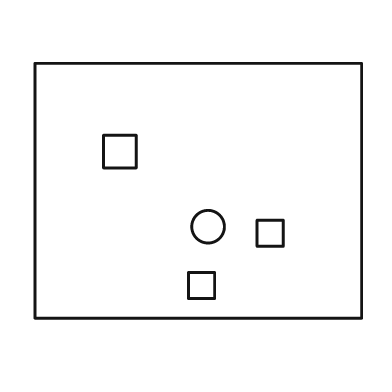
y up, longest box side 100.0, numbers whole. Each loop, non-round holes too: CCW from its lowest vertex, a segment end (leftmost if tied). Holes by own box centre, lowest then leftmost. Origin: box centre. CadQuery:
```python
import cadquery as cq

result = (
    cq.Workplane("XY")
    .moveTo(-50.0, -39.0)
    .lineTo(50.0, -39.0)
    .lineTo(50.0, 39.0)
    .lineTo(-50.0, 39.0)
    .close()
    .moveTo(-3.0, -33.0)
    .lineTo(5.0, -33.0)
    .lineTo(5.0, -25.0)
    .lineTo(-3.0, -25.0)
    .close()
    .moveTo(18.0, -17.0)
    .lineTo(26.0, -17.0)
    .lineTo(26.0, -9.0)
    .lineTo(18.0, -9.0)
    .close()
    .moveTo(3.0, -11.0)
    .circle(5.0)
    .moveTo(-29.0, 7.0)
    .lineTo(-19.0, 7.0)
    .lineTo(-19.0, 17.0)
    .lineTo(-29.0, 17.0)
    .close()
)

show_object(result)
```